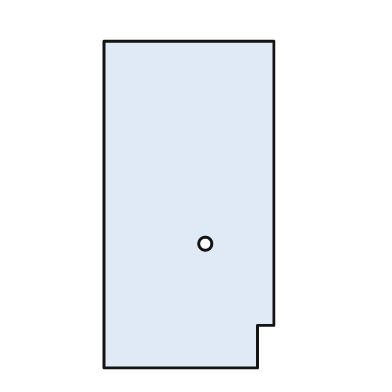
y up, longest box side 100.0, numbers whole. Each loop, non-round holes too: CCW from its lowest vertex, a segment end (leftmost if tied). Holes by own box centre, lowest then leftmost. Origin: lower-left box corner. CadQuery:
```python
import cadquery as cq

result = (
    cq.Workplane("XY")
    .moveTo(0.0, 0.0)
    .lineTo(47.0, 0.0)
    .lineTo(47.0, 13.0)
    .lineTo(52.0, 13.0)
    .lineTo(52.0, 100.0)
    .lineTo(0.0, 100.0)
    .close()
    .moveTo(31.0, 38.0)
    .circle(2.0)
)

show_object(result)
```